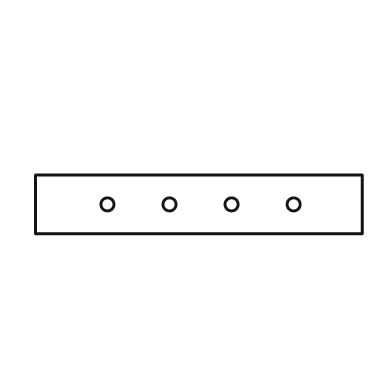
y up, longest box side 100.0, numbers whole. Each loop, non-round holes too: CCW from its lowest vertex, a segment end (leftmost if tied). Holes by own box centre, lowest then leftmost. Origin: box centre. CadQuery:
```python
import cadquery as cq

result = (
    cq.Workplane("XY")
    .moveTo(-50.0, -9.0)
    .lineTo(50.0, -9.0)
    .lineTo(50.0, 9.0)
    .lineTo(-50.0, 9.0)
    .close()
    .moveTo(-28.0, 0.0)
    .circle(2.0)
    .moveTo(-9.0, 0.0)
    .circle(2.0)
    .moveTo(10.0, 0.0)
    .circle(2.0)
    .moveTo(29.0, 0.0)
    .circle(2.0)
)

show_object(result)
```